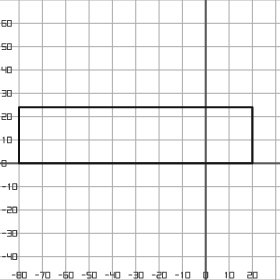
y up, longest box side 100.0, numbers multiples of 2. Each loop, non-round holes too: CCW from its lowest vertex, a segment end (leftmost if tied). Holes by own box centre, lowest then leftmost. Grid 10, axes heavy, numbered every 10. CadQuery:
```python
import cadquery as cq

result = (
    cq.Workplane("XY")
    .moveTo(-80.0, 0.0)
    .lineTo(20.0, 0.0)
    .lineTo(20.0, 24.0)
    .lineTo(-80.0, 24.0)
    .close()
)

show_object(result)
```